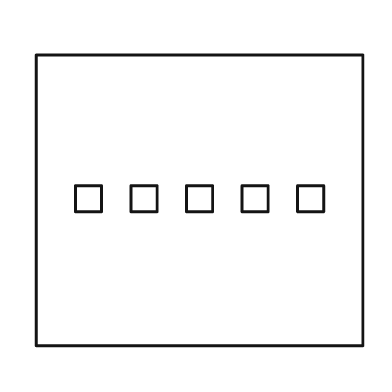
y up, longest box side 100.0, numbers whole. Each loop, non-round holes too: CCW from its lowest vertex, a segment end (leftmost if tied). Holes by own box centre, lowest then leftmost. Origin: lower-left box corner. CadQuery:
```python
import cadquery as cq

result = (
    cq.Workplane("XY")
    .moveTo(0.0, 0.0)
    .lineTo(100.0, 0.0)
    .lineTo(100.0, 89.0)
    .lineTo(0.0, 89.0)
    .close()
    .moveTo(12.0, 41.0)
    .lineTo(20.0, 41.0)
    .lineTo(20.0, 49.0)
    .lineTo(12.0, 49.0)
    .close()
    .moveTo(29.0, 41.0)
    .lineTo(37.0, 41.0)
    .lineTo(37.0, 49.0)
    .lineTo(29.0, 49.0)
    .close()
    .moveTo(46.0, 41.0)
    .lineTo(54.0, 41.0)
    .lineTo(54.0, 49.0)
    .lineTo(46.0, 49.0)
    .close()
    .moveTo(63.0, 41.0)
    .lineTo(71.0, 41.0)
    .lineTo(71.0, 49.0)
    .lineTo(63.0, 49.0)
    .close()
    .moveTo(80.0, 41.0)
    .lineTo(88.0, 41.0)
    .lineTo(88.0, 49.0)
    .lineTo(80.0, 49.0)
    .close()
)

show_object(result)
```